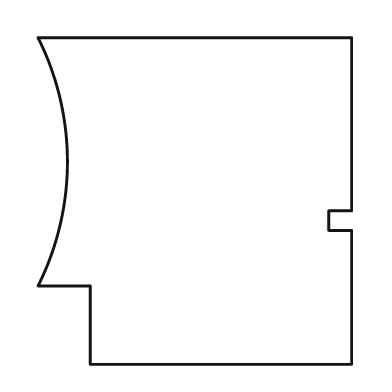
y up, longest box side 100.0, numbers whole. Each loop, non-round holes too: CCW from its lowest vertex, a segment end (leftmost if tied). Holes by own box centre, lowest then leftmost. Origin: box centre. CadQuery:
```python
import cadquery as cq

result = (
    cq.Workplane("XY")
    .moveTo(-32.0, -50.0)
    .lineTo(48.0, -50.0)
    .lineTo(48.0, -9.0)
    .lineTo(41.0, -9.0)
    .lineTo(41.0, -3.0)
    .lineTo(48.0, -3.0)
    .lineTo(48.0, 50.0)
    .lineTo(-48.0, 50.0)
    .threePointArc((-39.0, 12.0), (-48.0, -26.0))
    .lineTo(-32.0, -26.0)
    .close()
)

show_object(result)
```